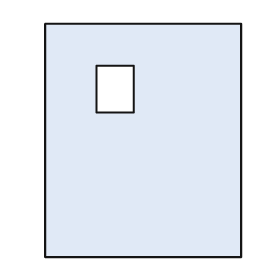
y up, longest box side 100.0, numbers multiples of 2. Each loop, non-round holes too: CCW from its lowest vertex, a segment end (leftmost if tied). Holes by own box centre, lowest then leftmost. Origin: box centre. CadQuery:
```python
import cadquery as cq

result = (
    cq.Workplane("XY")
    .moveTo(-42.0, -50.0)
    .lineTo(42.0, -50.0)
    .lineTo(42.0, 50.0)
    .lineTo(-42.0, 50.0)
    .close()
    .moveTo(-20.0, 12.0)
    .lineTo(-4.0, 12.0)
    .lineTo(-4.0, 32.0)
    .lineTo(-20.0, 32.0)
    .close()
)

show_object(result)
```